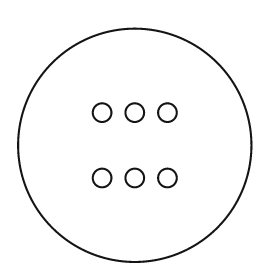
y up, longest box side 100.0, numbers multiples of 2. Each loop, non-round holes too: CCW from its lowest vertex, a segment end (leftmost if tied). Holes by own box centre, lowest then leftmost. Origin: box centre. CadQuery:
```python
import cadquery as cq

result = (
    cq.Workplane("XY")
    .moveTo(0.0, 0.0)
    .circle(50.0)
    .moveTo(-14.0, -14.0)
    .circle(4.0)
    .moveTo(0.0, -14.0)
    .circle(4.0)
    .moveTo(14.0, -14.0)
    .circle(4.0)
    .moveTo(-14.0, 14.0)
    .circle(4.0)
    .moveTo(0.0, 14.0)
    .circle(4.0)
    .moveTo(14.0, 14.0)
    .circle(4.0)
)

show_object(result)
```